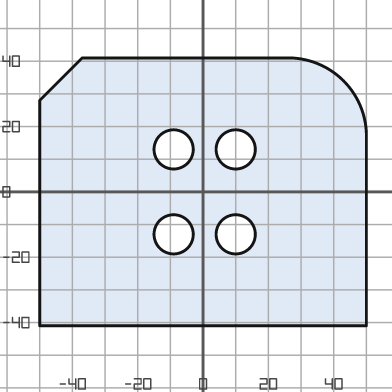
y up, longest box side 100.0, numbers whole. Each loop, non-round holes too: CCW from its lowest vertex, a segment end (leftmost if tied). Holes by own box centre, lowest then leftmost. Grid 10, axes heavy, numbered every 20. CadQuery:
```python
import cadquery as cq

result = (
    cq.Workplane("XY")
    .moveTo(-50.0, -41.0)
    .lineTo(50.0, -41.0)
    .lineTo(50.0, 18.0)
    .threePointArc((43.0, 34.0), (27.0, 41.0))
    .lineTo(-37.0, 41.0)
    .lineTo(-50.0, 28.0)
    .close()
    .moveTo(-9.0, -13.0)
    .circle(6.0)
    .moveTo(10.0, -13.0)
    .circle(6.0)
    .moveTo(-9.0, 13.0)
    .circle(6.0)
    .moveTo(10.0, 13.0)
    .circle(6.0)
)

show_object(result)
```